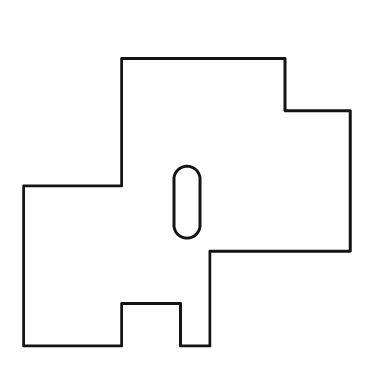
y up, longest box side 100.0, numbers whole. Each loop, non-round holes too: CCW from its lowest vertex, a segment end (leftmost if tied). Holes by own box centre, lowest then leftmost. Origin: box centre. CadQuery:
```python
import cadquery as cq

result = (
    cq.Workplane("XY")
    .moveTo(-50.0, -44.0)
    .lineTo(-20.0, -44.0)
    .lineTo(-20.0, -31.0)
    .lineTo(-2.0, -31.0)
    .lineTo(-2.0, -44.0)
    .lineTo(7.0, -44.0)
    .lineTo(7.0, -15.0)
    .lineTo(50.0, -15.0)
    .lineTo(50.0, 28.0)
    .lineTo(30.0, 28.0)
    .lineTo(30.0, 44.0)
    .lineTo(-20.0, 44.0)
    .lineTo(-20.0, 5.0)
    .lineTo(-50.0, 5.0)
    .close()
    .moveTo(-4.0, -7.0)
    .threePointArc((0.0, -11.0), (4.0, -7.0))
    .lineTo(4.0, 7.0)
    .threePointArc((0.0, 11.0), (-4.0, 7.0))
    .close()
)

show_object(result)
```